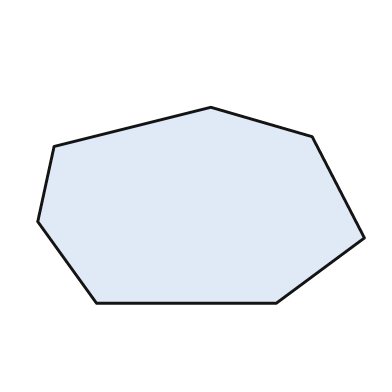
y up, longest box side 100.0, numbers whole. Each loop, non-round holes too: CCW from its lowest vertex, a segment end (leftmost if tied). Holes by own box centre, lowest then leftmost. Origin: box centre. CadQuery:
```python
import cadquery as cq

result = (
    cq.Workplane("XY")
    .moveTo(-32.0, -30.0)
    .lineTo(23.0, -30.0)
    .lineTo(50.0, -10.0)
    .lineTo(34.0, 21.0)
    .lineTo(3.0, 30.0)
    .lineTo(-45.0, 18.0)
    .lineTo(-50.0, -5.0)
    .close()
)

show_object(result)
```